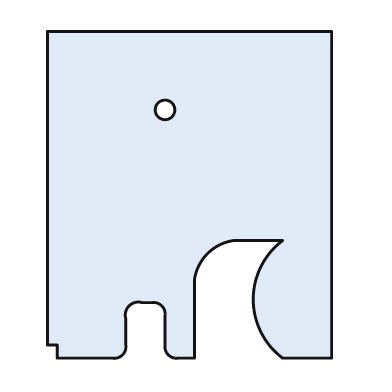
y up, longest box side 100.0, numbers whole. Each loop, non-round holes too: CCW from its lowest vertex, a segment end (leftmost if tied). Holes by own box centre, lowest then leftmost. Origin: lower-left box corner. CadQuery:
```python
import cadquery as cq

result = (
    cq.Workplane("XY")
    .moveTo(3.0, 0.0)
    .lineTo(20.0, 0.0)
    .threePointArc((23.0, 1.0), (24.0, 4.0))
    .lineTo(24.0, 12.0)
    .threePointArc((25.0, 16.0), (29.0, 17.0))
    .lineTo(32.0, 17.0)
    .threePointArc((35.0, 16.0), (36.0, 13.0))
    .lineTo(36.0, 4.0)
    .threePointArc((37.0, 1.0), (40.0, 0.0))
    .lineTo(45.0, 0.0)
    .lineTo(45.0, 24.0)
    .threePointArc((49.0, 32.0), (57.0, 36.0))
    .lineTo(72.0, 36.0)
    .threePointArc((63.0, 18.0), (72.0, 0.0))
    .lineTo(87.0, 0.0)
    .lineTo(87.0, 100.0)
    .lineTo(0.0, 100.0)
    .lineTo(0.0, 4.0)
    .lineTo(3.0, 4.0)
    .close()
    .moveTo(36.0, 76.0)
    .circle(3.0)
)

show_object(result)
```